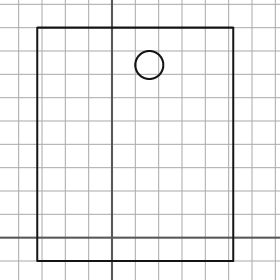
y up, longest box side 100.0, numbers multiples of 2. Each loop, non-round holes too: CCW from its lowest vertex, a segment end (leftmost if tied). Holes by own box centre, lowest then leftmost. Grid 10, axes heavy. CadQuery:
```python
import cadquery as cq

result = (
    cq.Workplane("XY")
    .moveTo(-32.0, -10.0)
    .lineTo(52.0, -10.0)
    .lineTo(52.0, 90.0)
    .lineTo(-32.0, 90.0)
    .close()
    .moveTo(16.0, 74.0)
    .circle(6.0)
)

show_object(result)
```